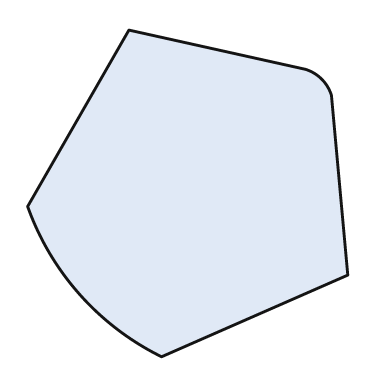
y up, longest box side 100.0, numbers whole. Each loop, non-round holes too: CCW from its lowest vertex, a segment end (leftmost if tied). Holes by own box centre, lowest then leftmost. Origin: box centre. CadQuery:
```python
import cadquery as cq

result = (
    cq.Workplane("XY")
    .moveTo(-8.0, -50.0)
    .lineTo(49.0, -25.0)
    .lineTo(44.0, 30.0)
    .threePointArc((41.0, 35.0), (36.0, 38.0))
    .lineTo(-18.0, 50.0)
    .lineTo(-49.0, -4.0)
    .threePointArc((-33.0, -31.0), (-8.0, -50.0))
    .close()
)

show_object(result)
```